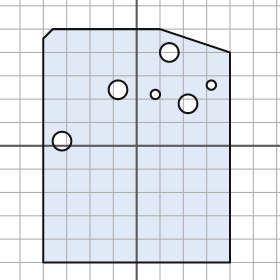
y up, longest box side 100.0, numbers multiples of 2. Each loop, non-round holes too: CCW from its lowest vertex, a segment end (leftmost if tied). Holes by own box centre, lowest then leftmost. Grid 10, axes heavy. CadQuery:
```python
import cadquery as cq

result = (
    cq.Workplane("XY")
    .moveTo(-40.0, -50.0)
    .lineTo(40.0, -50.0)
    .lineTo(40.0, 40.0)
    .lineTo(10.0, 50.0)
    .lineTo(-36.0, 50.0)
    .lineTo(-40.0, 46.0)
    .close()
    .moveTo(-32.0, 2.0)
    .circle(4.0)
    .moveTo(22.0, 18.0)
    .circle(4.0)
    .moveTo(8.0, 22.0)
    .circle(2.0)
    .moveTo(-8.0, 24.0)
    .circle(4.0)
    .moveTo(32.0, 26.0)
    .circle(2.0)
    .moveTo(14.0, 40.0)
    .circle(4.0)
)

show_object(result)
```